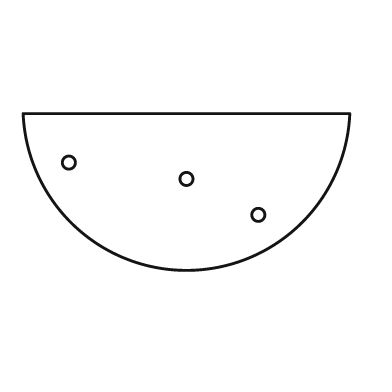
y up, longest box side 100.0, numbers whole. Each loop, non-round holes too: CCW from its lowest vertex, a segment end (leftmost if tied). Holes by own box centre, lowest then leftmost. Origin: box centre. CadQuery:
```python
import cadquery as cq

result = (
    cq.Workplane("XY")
    .moveTo(-50.0, 24.0)
    .threePointArc((0.0, -24.0), (50.0, 24.0))
    .close()
    .moveTo(22.0, -7.0)
    .circle(2.0)
    .moveTo(0.0, 4.0)
    .circle(2.0)
    .moveTo(-36.0, 9.0)
    .circle(2.0)
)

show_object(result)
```